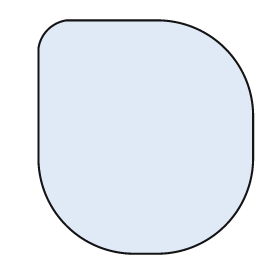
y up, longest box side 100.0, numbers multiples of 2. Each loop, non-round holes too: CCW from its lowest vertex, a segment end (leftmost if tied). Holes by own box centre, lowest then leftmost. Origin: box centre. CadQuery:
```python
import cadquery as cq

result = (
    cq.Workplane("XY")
    .moveTo(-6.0, -50.0)
    .lineTo(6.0, -50.0)
    .threePointArc((34.0, -38.0), (46.0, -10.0))
    .lineTo(46.0, 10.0)
    .threePointArc((34.0, 38.0), (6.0, 50.0))
    .lineTo(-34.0, 50.0)
    .threePointArc((-42.0, 46.0), (-46.0, 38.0))
    .lineTo(-46.0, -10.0)
    .threePointArc((-34.0, -38.0), (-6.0, -50.0))
    .close()
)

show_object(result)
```